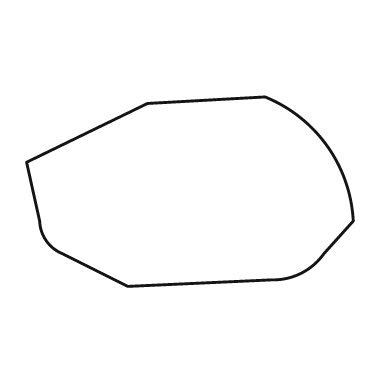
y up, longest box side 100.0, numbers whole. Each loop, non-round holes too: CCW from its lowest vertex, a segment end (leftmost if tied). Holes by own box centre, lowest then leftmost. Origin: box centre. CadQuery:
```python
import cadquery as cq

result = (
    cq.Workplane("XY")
    .moveTo(-19.0, -29.0)
    .lineTo(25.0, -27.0)
    .threePointArc((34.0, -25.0), (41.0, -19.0))
    .lineTo(50.0, -9.0)
    .threePointArc((42.0, 14.0), (23.0, 29.0))
    .lineTo(-13.0, 27.0)
    .lineTo(-50.0, 9.0)
    .lineTo(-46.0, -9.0)
    .threePointArc((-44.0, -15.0), (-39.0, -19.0))
    .close()
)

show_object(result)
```